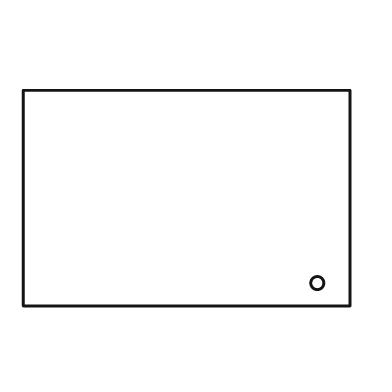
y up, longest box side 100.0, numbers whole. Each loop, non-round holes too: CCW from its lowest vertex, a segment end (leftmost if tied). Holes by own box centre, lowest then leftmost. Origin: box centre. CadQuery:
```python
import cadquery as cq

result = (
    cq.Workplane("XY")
    .moveTo(-50.0, -33.0)
    .lineTo(50.0, -33.0)
    .lineTo(50.0, 33.0)
    .lineTo(-50.0, 33.0)
    .close()
    .moveTo(40.0, -26.0)
    .circle(2.0)
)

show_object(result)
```